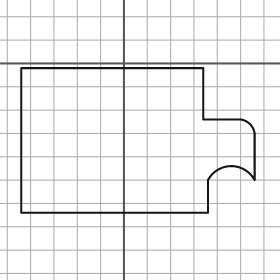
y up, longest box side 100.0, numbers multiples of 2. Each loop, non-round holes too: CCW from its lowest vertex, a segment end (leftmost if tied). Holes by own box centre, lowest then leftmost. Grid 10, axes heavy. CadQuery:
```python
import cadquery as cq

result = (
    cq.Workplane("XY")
    .moveTo(-44.0, -64.0)
    .lineTo(36.0, -64.0)
    .lineTo(36.0, -50.0)
    .threePointArc((46.0, -44.0), (56.0, -50.0))
    .lineTo(56.0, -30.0)
    .threePointArc((54.0, -26.0), (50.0, -24.0))
    .lineTo(34.0, -24.0)
    .lineTo(34.0, -2.0)
    .lineTo(-44.0, -2.0)
    .close()
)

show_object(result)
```